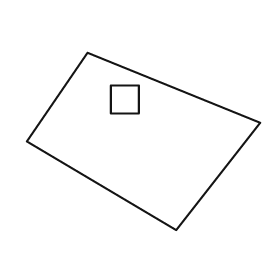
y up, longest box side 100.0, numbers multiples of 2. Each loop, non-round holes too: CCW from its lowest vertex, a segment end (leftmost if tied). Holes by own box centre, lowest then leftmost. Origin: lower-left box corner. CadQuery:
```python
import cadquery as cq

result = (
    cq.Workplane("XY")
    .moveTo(64.0, 0.0)
    .lineTo(100.0, 46.0)
    .lineTo(26.0, 76.0)
    .lineTo(0.0, 38.0)
    .close()
    .moveTo(36.0, 50.0)
    .lineTo(48.0, 50.0)
    .lineTo(48.0, 62.0)
    .lineTo(36.0, 62.0)
    .close()
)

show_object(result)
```